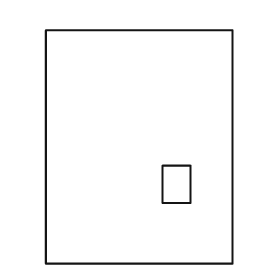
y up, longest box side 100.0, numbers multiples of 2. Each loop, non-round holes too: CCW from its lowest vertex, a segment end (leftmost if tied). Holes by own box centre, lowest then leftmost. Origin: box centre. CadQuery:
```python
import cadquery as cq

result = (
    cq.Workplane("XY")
    .moveTo(-40.0, -50.0)
    .lineTo(40.0, -50.0)
    .lineTo(40.0, 50.0)
    .lineTo(-40.0, 50.0)
    .close()
    .moveTo(10.0, -24.0)
    .lineTo(22.0, -24.0)
    .lineTo(22.0, -8.0)
    .lineTo(10.0, -8.0)
    .close()
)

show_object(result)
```